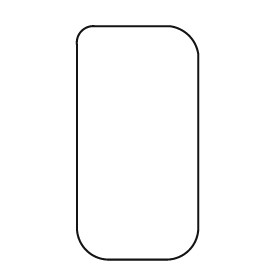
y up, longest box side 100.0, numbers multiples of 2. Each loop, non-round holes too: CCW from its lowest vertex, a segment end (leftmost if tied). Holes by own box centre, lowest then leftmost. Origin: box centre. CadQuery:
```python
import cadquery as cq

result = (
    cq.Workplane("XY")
    .moveTo(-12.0, -50.0)
    .lineTo(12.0, -50.0)
    .threePointArc((22.0, -46.0), (26.0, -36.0))
    .lineTo(26.0, 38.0)
    .threePointArc((22.0, 46.0), (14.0, 50.0))
    .lineTo(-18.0, 50.0)
    .threePointArc((-24.0, 48.0), (-26.0, 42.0))
    .lineTo(-26.0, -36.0)
    .threePointArc((-22.0, -46.0), (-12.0, -50.0))
    .close()
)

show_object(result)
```